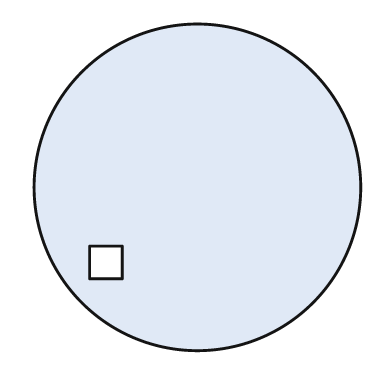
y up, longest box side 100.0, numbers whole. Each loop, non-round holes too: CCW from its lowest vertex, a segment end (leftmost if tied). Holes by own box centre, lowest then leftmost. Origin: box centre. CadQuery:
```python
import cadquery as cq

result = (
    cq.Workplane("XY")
    .moveTo(0.0, 0.0)
    .circle(50.0)
    .moveTo(-33.0, -28.0)
    .lineTo(-23.0, -28.0)
    .lineTo(-23.0, -18.0)
    .lineTo(-33.0, -18.0)
    .close()
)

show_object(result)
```